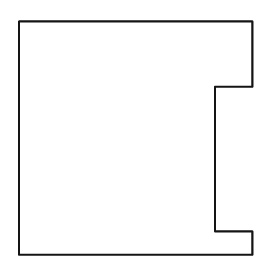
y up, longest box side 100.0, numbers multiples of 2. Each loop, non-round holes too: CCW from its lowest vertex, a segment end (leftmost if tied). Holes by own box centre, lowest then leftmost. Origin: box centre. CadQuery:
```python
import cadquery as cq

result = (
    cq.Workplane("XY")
    .moveTo(-50.0, -50.0)
    .lineTo(50.0, -50.0)
    .lineTo(50.0, -40.0)
    .lineTo(34.0, -40.0)
    .lineTo(34.0, 22.0)
    .lineTo(50.0, 22.0)
    .lineTo(50.0, 50.0)
    .lineTo(-50.0, 50.0)
    .close()
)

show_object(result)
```